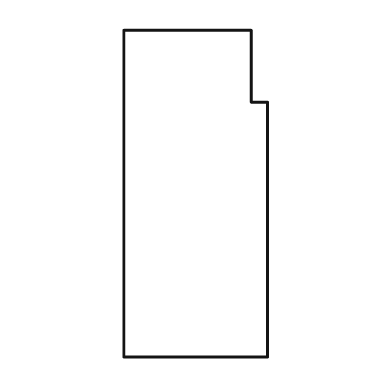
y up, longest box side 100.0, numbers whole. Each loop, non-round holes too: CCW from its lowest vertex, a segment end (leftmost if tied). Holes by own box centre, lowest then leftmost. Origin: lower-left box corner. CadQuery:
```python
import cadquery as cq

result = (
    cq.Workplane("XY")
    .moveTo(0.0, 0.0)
    .lineTo(44.0, 0.0)
    .lineTo(44.0, 78.0)
    .lineTo(39.0, 78.0)
    .lineTo(39.0, 100.0)
    .lineTo(0.0, 100.0)
    .close()
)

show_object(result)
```